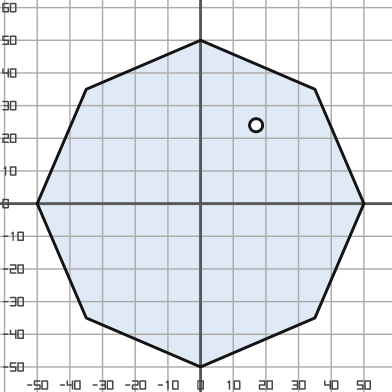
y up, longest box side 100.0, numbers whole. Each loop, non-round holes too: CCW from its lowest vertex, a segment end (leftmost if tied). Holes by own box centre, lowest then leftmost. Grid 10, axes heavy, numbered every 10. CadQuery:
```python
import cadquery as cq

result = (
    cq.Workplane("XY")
    .moveTo(0.0, -50.0)
    .lineTo(35.0, -35.0)
    .lineTo(50.0, 0.0)
    .lineTo(35.0, 35.0)
    .lineTo(0.0, 50.0)
    .lineTo(-35.0, 35.0)
    .lineTo(-50.0, 0.0)
    .lineTo(-35.0, -35.0)
    .close()
    .moveTo(17.0, 24.0)
    .circle(2.0)
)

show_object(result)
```